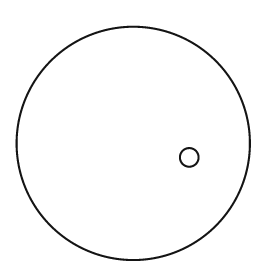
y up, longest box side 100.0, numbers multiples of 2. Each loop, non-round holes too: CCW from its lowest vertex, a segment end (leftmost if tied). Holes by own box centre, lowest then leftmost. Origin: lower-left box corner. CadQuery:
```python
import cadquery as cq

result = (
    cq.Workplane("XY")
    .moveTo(50.0, 50.0)
    .circle(50.0)
    .moveTo(74.0, 44.0)
    .circle(4.0)
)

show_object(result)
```